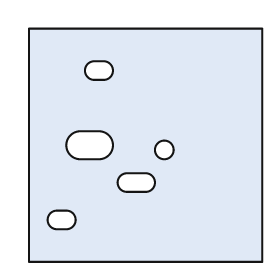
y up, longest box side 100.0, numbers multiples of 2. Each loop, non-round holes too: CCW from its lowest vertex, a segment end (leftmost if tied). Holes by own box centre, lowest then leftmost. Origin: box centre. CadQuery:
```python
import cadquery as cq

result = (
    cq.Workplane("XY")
    .moveTo(-50.0, -50.0)
    .lineTo(50.0, -50.0)
    .lineTo(50.0, 50.0)
    .lineTo(-50.0, 50.0)
    .close()
    .moveTo(-38.0, -36.0)
    .lineTo(-34.0, -36.0)
    .threePointArc((-30.0, -32.0), (-34.0, -28.0))
    .lineTo(-38.0, -28.0)
    .threePointArc((-42.0, -32.0), (-38.0, -36.0))
    .close()
    .moveTo(-8.0, -20.0)
    .lineTo(0.0, -20.0)
    .threePointArc((4.0, -16.0), (0.0, -12.0))
    .lineTo(-8.0, -12.0)
    .threePointArc((-12.0, -16.0), (-8.0, -20.0))
    .close()
    .moveTo(8.0, -2.0)
    .circle(4.0)
    .moveTo(-28.0, -6.0)
    .lineTo(-20.0, -6.0)
    .threePointArc((-14.0, 0.0), (-20.0, 6.0))
    .lineTo(-28.0, 6.0)
    .threePointArc((-34.0, 0.0), (-28.0, -6.0))
    .close()
    .moveTo(-22.0, 28.0)
    .lineTo(-18.0, 28.0)
    .threePointArc((-14.0, 32.0), (-18.0, 36.0))
    .lineTo(-22.0, 36.0)
    .threePointArc((-26.0, 32.0), (-22.0, 28.0))
    .close()
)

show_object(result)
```